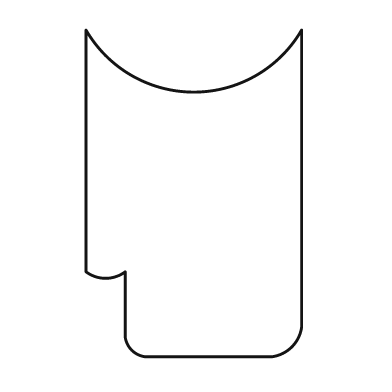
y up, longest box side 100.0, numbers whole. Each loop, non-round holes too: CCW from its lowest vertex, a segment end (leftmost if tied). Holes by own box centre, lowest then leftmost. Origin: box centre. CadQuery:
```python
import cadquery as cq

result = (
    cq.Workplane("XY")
    .moveTo(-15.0, -50.0)
    .lineTo(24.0, -50.0)
    .threePointArc((30.0, -47.0), (33.0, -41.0))
    .lineTo(33.0, 50.0)
    .threePointArc((0.0, 31.0), (-33.0, 50.0))
    .lineTo(-33.0, -24.0)
    .threePointArc((-27.0, -26.0), (-21.0, -24.0))
    .lineTo(-21.0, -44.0)
    .threePointArc((-19.0, -48.0), (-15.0, -50.0))
    .close()
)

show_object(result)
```